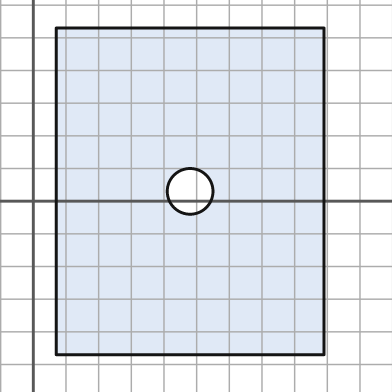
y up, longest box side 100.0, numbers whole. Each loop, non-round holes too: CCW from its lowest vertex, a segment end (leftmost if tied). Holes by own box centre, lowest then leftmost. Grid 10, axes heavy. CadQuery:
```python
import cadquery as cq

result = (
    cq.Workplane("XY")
    .moveTo(7.0, -47.0)
    .lineTo(89.0, -47.0)
    .lineTo(89.0, 53.0)
    .lineTo(7.0, 53.0)
    .close()
    .moveTo(48.0, 3.0)
    .circle(7.0)
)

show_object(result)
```